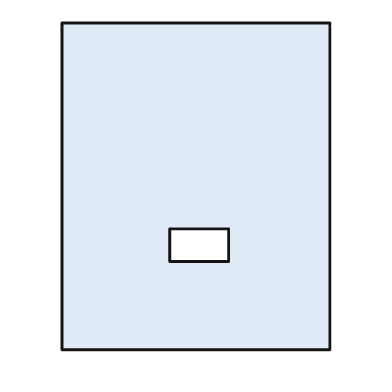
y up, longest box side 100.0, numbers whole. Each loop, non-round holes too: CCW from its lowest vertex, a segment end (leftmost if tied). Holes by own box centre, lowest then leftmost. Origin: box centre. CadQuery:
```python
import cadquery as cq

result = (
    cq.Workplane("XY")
    .moveTo(-41.0, -50.0)
    .lineTo(41.0, -50.0)
    .lineTo(41.0, 50.0)
    .lineTo(-41.0, 50.0)
    .close()
    .moveTo(-8.0, -23.0)
    .lineTo(10.0, -23.0)
    .lineTo(10.0, -13.0)
    .lineTo(-8.0, -13.0)
    .close()
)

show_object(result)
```